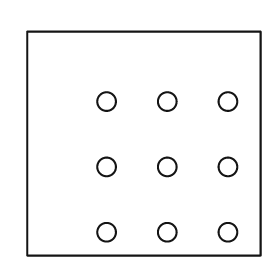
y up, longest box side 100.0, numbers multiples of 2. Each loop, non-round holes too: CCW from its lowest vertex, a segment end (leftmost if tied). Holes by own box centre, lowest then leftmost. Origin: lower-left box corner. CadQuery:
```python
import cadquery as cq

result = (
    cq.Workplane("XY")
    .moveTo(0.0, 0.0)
    .lineTo(100.0, 0.0)
    .lineTo(100.0, 96.0)
    .lineTo(0.0, 96.0)
    .close()
    .moveTo(34.0, 10.0)
    .circle(4.0)
    .moveTo(60.0, 10.0)
    .circle(4.0)
    .moveTo(86.0, 10.0)
    .circle(4.0)
    .moveTo(34.0, 38.0)
    .circle(4.0)
    .moveTo(60.0, 38.0)
    .circle(4.0)
    .moveTo(86.0, 38.0)
    .circle(4.0)
    .moveTo(34.0, 66.0)
    .circle(4.0)
    .moveTo(60.0, 66.0)
    .circle(4.0)
    .moveTo(86.0, 66.0)
    .circle(4.0)
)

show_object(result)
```